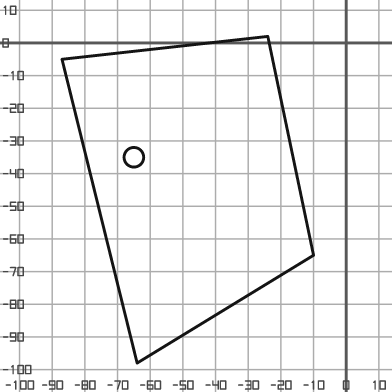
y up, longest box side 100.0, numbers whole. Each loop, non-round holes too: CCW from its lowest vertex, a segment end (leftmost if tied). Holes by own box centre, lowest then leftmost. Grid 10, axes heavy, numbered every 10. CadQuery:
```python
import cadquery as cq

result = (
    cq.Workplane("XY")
    .moveTo(-64.0, -98.0)
    .lineTo(-10.0, -65.0)
    .lineTo(-24.0, 2.0)
    .lineTo(-87.0, -5.0)
    .close()
    .moveTo(-65.0, -35.0)
    .circle(3.0)
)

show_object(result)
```